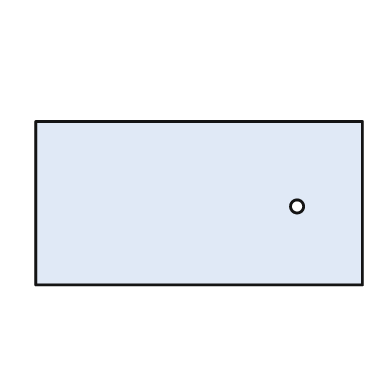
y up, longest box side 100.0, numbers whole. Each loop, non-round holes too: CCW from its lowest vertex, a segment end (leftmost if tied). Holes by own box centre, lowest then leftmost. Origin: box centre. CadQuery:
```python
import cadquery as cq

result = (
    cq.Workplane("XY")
    .moveTo(-50.0, -25.0)
    .lineTo(50.0, -25.0)
    .lineTo(50.0, 25.0)
    .lineTo(-50.0, 25.0)
    .close()
    .moveTo(30.0, -1.0)
    .circle(2.0)
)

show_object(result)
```